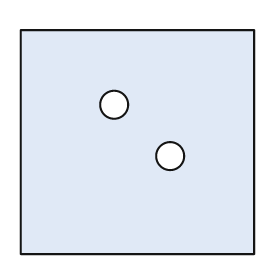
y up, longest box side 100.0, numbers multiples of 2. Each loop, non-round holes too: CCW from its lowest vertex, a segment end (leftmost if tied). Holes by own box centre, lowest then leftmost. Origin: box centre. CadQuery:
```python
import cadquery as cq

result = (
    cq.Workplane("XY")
    .moveTo(-50.0, -48.0)
    .lineTo(50.0, -48.0)
    .lineTo(50.0, 48.0)
    .lineTo(-50.0, 48.0)
    .close()
    .moveTo(14.0, -6.0)
    .circle(6.0)
    .moveTo(-10.0, 16.0)
    .circle(6.0)
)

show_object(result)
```